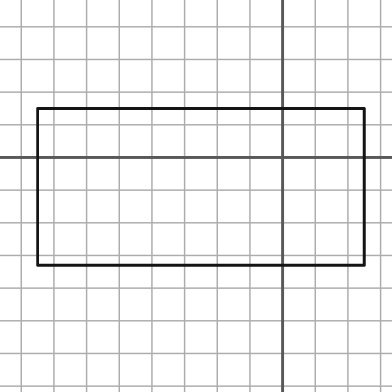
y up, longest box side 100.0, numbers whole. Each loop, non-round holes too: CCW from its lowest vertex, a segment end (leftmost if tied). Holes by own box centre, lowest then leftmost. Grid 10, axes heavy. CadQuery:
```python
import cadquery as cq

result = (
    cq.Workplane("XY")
    .moveTo(-75.0, -33.0)
    .lineTo(25.0, -33.0)
    .lineTo(25.0, 15.0)
    .lineTo(-75.0, 15.0)
    .close()
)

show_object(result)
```